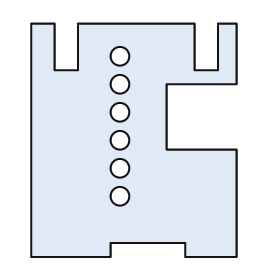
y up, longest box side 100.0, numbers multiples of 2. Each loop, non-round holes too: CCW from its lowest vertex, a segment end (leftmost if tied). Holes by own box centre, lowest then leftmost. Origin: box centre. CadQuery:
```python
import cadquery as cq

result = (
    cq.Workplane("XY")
    .moveTo(-44.0, -50.0)
    .lineTo(-10.0, -50.0)
    .lineTo(-10.0, -44.0)
    .lineTo(22.0, -44.0)
    .lineTo(22.0, -50.0)
    .lineTo(44.0, -50.0)
    .lineTo(44.0, -4.0)
    .lineTo(14.0, -4.0)
    .lineTo(14.0, 24.0)
    .lineTo(44.0, 24.0)
    .lineTo(44.0, 50.0)
    .lineTo(36.0, 50.0)
    .lineTo(36.0, 30.0)
    .lineTo(26.0, 30.0)
    .lineTo(26.0, 50.0)
    .lineTo(-24.0, 50.0)
    .lineTo(-24.0, 30.0)
    .lineTo(-34.0, 30.0)
    .lineTo(-34.0, 50.0)
    .lineTo(-44.0, 50.0)
    .close()
    .moveTo(-6.0, -24.0)
    .circle(4.0)
    .moveTo(-6.0, -12.0)
    .circle(4.0)
    .moveTo(-6.0, 0.0)
    .circle(4.0)
    .moveTo(-6.0, 12.0)
    .circle(4.0)
    .moveTo(-6.0, 24.0)
    .circle(4.0)
    .moveTo(-6.0, 36.0)
    .circle(4.0)
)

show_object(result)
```